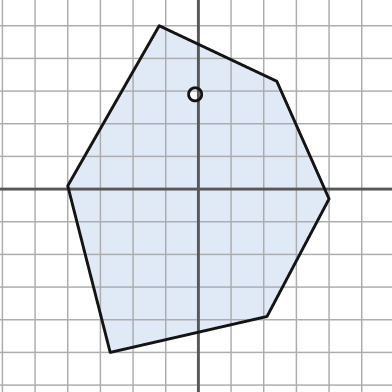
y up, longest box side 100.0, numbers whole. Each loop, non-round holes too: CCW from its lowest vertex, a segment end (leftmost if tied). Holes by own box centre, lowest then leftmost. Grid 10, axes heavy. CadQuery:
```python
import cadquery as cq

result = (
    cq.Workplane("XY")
    .moveTo(-27.0, -50.0)
    .lineTo(21.0, -39.0)
    .lineTo(40.0, -3.0)
    .lineTo(24.0, 33.0)
    .lineTo(-12.0, 50.0)
    .lineTo(-40.0, 1.0)
    .close()
    .moveTo(-1.0, 29.0)
    .circle(2.0)
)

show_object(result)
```